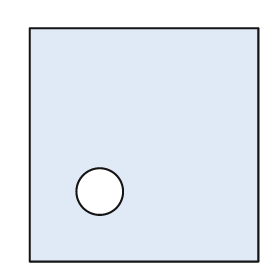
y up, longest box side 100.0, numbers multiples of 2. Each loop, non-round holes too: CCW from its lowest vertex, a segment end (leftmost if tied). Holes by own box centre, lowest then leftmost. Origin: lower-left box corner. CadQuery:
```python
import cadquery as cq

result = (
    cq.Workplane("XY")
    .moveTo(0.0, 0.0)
    .lineTo(98.0, 0.0)
    .lineTo(98.0, 100.0)
    .lineTo(0.0, 100.0)
    .close()
    .moveTo(30.0, 30.0)
    .circle(10.0)
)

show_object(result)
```